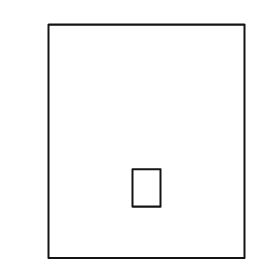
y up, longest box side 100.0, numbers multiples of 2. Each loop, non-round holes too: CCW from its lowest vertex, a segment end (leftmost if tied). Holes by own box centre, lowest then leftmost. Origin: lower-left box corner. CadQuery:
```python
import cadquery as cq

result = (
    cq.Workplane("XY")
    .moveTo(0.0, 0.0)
    .lineTo(84.0, 0.0)
    .lineTo(84.0, 100.0)
    .lineTo(0.0, 100.0)
    .close()
    .moveTo(36.0, 22.0)
    .lineTo(48.0, 22.0)
    .lineTo(48.0, 38.0)
    .lineTo(36.0, 38.0)
    .close()
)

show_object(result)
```